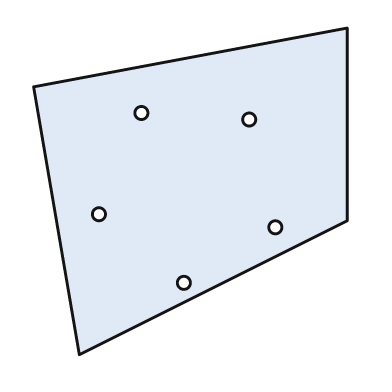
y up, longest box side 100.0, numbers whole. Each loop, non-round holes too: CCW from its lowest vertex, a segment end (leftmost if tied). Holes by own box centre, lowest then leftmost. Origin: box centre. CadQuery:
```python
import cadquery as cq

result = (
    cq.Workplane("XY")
    .moveTo(-34.0, -50.0)
    .lineTo(48.0, -9.0)
    .lineTo(48.0, 50.0)
    .lineTo(-48.0, 32.0)
    .close()
    .moveTo(-2.0, -28.0)
    .circle(2.0)
    .moveTo(26.0, -11.0)
    .circle(2.0)
    .moveTo(-28.0, -7.0)
    .circle(2.0)
    .moveTo(18.0, 22.0)
    .circle(2.0)
    .moveTo(-15.0, 24.0)
    .circle(2.0)
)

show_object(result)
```